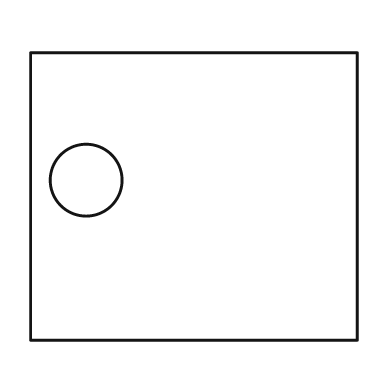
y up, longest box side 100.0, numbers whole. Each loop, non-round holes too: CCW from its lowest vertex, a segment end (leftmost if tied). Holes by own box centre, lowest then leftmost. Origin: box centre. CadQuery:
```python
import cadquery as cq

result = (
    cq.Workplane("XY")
    .moveTo(-50.0, -44.0)
    .lineTo(50.0, -44.0)
    .lineTo(50.0, 44.0)
    .lineTo(-50.0, 44.0)
    .close()
    .moveTo(-33.0, 5.0)
    .circle(11.0)
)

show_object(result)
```